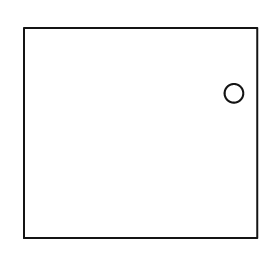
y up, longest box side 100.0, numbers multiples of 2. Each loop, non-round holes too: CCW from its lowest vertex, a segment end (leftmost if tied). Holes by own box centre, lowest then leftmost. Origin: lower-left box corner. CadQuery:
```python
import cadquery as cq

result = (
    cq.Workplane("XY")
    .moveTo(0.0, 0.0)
    .lineTo(100.0, 0.0)
    .lineTo(100.0, 90.0)
    .lineTo(0.0, 90.0)
    .close()
    .moveTo(90.0, 62.0)
    .circle(4.0)
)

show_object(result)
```